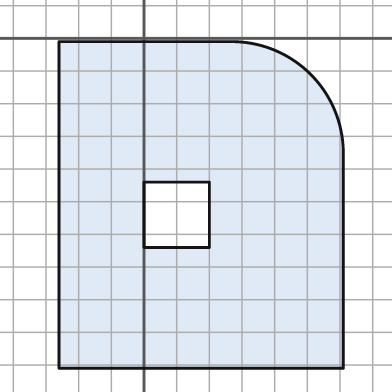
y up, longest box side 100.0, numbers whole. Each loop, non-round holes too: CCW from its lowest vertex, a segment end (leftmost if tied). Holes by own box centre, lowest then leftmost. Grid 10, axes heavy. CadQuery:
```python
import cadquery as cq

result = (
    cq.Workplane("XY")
    .moveTo(-26.0, -101.0)
    .lineTo(61.0, -101.0)
    .lineTo(61.0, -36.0)
    .threePointArc((51.0, -11.0), (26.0, -1.0))
    .lineTo(-26.0, -1.0)
    .close()
    .moveTo(0.0, -64.0)
    .lineTo(20.0, -64.0)
    .lineTo(20.0, -44.0)
    .lineTo(0.0, -44.0)
    .close()
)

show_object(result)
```